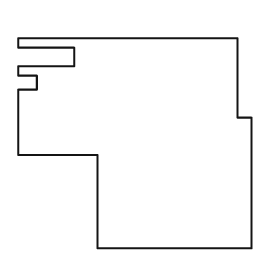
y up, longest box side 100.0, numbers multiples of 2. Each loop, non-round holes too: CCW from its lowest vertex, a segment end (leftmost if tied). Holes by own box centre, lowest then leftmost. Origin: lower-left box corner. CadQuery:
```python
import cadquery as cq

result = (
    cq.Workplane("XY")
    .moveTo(34.0, 0.0)
    .lineTo(100.0, 0.0)
    .lineTo(100.0, 56.0)
    .lineTo(94.0, 56.0)
    .lineTo(94.0, 90.0)
    .lineTo(0.0, 90.0)
    .lineTo(0.0, 86.0)
    .lineTo(24.0, 86.0)
    .lineTo(24.0, 78.0)
    .lineTo(0.0, 78.0)
    .lineTo(0.0, 74.0)
    .lineTo(8.0, 74.0)
    .lineTo(8.0, 68.0)
    .lineTo(0.0, 68.0)
    .lineTo(0.0, 40.0)
    .lineTo(34.0, 40.0)
    .close()
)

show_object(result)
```